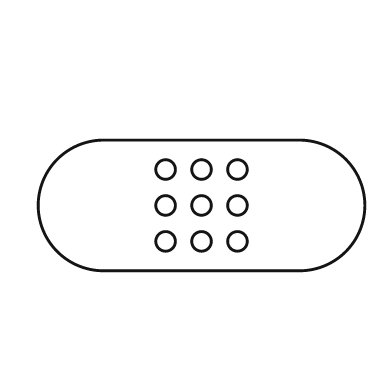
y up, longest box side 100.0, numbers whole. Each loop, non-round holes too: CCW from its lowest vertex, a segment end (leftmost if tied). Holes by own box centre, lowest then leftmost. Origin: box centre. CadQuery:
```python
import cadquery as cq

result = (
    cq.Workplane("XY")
    .moveTo(-30.0, -20.0)
    .lineTo(30.0, -20.0)
    .threePointArc((50.0, 0.0), (30.0, 20.0))
    .lineTo(-30.0, 20.0)
    .threePointArc((-50.0, 0.0), (-30.0, -20.0))
    .close()
    .moveTo(-11.0, -11.0)
    .circle(3.0)
    .moveTo(0.0, -11.0)
    .circle(3.0)
    .moveTo(11.0, -11.0)
    .circle(3.0)
    .moveTo(-11.0, 0.0)
    .circle(3.0)
    .moveTo(0.0, 0.0)
    .circle(3.0)
    .moveTo(11.0, 0.0)
    .circle(3.0)
    .moveTo(-11.0, 11.0)
    .circle(3.0)
    .moveTo(0.0, 11.0)
    .circle(3.0)
    .moveTo(11.0, 11.0)
    .circle(3.0)
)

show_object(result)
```